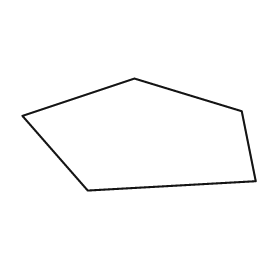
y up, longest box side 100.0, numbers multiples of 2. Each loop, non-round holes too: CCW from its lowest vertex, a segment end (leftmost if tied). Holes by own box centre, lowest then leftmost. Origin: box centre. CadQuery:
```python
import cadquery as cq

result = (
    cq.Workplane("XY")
    .moveTo(-22.0, -24.0)
    .lineTo(50.0, -20.0)
    .lineTo(44.0, 10.0)
    .lineTo(-2.0, 24.0)
    .lineTo(-50.0, 8.0)
    .close()
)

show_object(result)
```